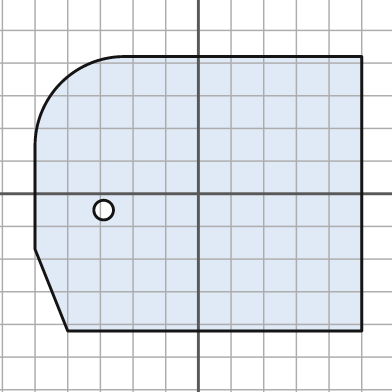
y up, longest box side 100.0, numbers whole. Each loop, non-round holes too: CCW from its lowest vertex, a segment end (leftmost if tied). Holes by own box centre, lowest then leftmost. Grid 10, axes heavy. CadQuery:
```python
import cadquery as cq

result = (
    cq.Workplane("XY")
    .moveTo(-40.0, -42.0)
    .lineTo(50.0, -42.0)
    .lineTo(50.0, 42.0)
    .lineTo(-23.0, 42.0)
    .threePointArc((-42.0, 34.0), (-50.0, 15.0))
    .lineTo(-50.0, -17.0)
    .close()
    .moveTo(-29.0, -5.0)
    .circle(3.0)
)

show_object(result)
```